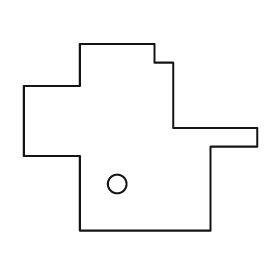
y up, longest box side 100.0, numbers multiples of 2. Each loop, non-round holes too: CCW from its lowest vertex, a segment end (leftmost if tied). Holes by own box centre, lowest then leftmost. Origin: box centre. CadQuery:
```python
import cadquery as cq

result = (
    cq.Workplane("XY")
    .moveTo(-26.0, -40.0)
    .lineTo(30.0, -40.0)
    .lineTo(30.0, -4.0)
    .lineTo(50.0, -4.0)
    .lineTo(50.0, 4.0)
    .lineTo(14.0, 4.0)
    .lineTo(14.0, 32.0)
    .lineTo(6.0, 32.0)
    .lineTo(6.0, 40.0)
    .lineTo(-26.0, 40.0)
    .lineTo(-26.0, 22.0)
    .lineTo(-50.0, 22.0)
    .lineTo(-50.0, -8.0)
    .lineTo(-26.0, -8.0)
    .close()
    .moveTo(-10.0, -20.0)
    .circle(4.0)
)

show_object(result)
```